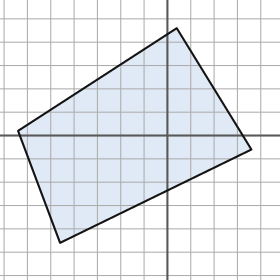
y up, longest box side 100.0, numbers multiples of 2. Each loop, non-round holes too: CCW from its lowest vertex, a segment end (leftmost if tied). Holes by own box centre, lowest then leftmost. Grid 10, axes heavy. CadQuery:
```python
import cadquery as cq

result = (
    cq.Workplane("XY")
    .moveTo(-46.0, -46.0)
    .lineTo(36.0, -6.0)
    .lineTo(4.0, 46.0)
    .lineTo(-64.0, 2.0)
    .close()
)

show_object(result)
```